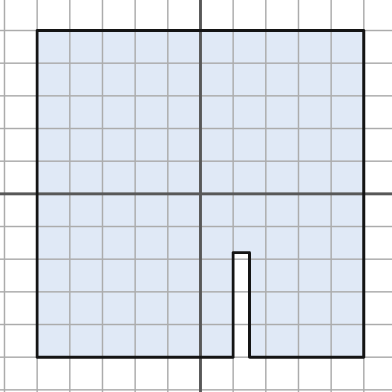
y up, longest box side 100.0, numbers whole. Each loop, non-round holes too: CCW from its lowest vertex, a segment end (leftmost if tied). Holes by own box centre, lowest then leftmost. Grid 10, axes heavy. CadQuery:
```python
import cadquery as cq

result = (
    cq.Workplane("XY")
    .moveTo(-50.0, -50.0)
    .lineTo(10.0, -50.0)
    .lineTo(10.0, -18.0)
    .lineTo(15.0, -18.0)
    .lineTo(15.0, -50.0)
    .lineTo(50.0, -50.0)
    .lineTo(50.0, 50.0)
    .lineTo(-50.0, 50.0)
    .close()
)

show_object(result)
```